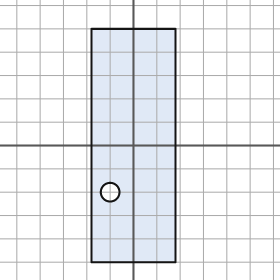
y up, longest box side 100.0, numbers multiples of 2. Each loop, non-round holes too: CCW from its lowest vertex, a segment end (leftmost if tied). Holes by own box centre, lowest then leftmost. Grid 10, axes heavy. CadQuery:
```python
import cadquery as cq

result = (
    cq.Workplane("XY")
    .moveTo(-18.0, -50.0)
    .lineTo(18.0, -50.0)
    .lineTo(18.0, 50.0)
    .lineTo(-18.0, 50.0)
    .close()
    .moveTo(-10.0, -20.0)
    .circle(4.0)
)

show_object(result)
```